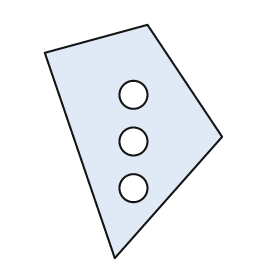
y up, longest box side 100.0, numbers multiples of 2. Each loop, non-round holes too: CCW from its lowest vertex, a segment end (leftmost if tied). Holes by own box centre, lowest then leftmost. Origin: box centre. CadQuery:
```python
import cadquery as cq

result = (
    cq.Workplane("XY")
    .moveTo(-8.0, -50.0)
    .lineTo(38.0, 2.0)
    .lineTo(6.0, 50.0)
    .lineTo(-38.0, 38.0)
    .close()
    .moveTo(0.0, -20.0)
    .circle(6.0)
    .moveTo(0.0, 0.0)
    .circle(6.0)
    .moveTo(0.0, 20.0)
    .circle(6.0)
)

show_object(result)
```